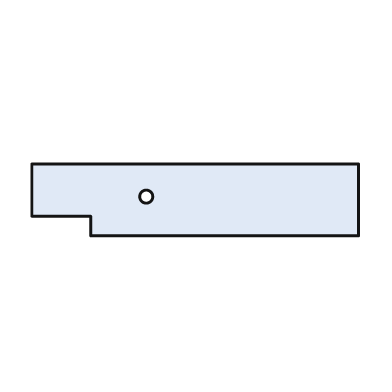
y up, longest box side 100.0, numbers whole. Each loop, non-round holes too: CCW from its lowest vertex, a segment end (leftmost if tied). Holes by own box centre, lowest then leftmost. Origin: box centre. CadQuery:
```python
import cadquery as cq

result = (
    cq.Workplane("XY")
    .moveTo(-32.0, -11.0)
    .lineTo(50.0, -11.0)
    .lineTo(50.0, 11.0)
    .lineTo(-50.0, 11.0)
    .lineTo(-50.0, -5.0)
    .lineTo(-32.0, -5.0)
    .close()
    .moveTo(-15.0, 1.0)
    .circle(2.0)
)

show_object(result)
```